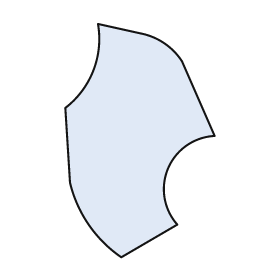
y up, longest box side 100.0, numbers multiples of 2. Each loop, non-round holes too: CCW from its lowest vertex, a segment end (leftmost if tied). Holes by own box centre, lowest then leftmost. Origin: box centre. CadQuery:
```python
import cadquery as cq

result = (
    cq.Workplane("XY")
    .moveTo(-8.0, -50.0)
    .lineTo(16.0, -36.0)
    .threePointArc((12.0, -12.0), (32.0, 2.0))
    .lineTo(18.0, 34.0)
    .threePointArc((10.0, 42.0), (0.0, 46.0))
    .lineTo(-18.0, 50.0)
    .threePointArc((-20.0, 30.0), (-32.0, 14.0))
    .lineTo(-30.0, -18.0)
    .threePointArc((-22.0, -36.0), (-8.0, -50.0))
    .close()
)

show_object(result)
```